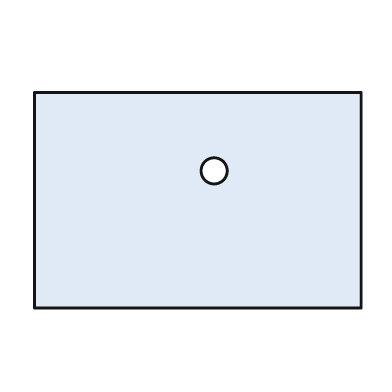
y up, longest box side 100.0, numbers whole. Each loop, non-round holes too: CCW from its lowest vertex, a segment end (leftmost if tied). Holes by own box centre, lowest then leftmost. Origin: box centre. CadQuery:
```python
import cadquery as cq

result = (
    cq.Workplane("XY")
    .moveTo(-50.0, -33.0)
    .lineTo(50.0, -33.0)
    .lineTo(50.0, 33.0)
    .lineTo(-50.0, 33.0)
    .close()
    .moveTo(5.0, 9.0)
    .circle(4.0)
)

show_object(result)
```